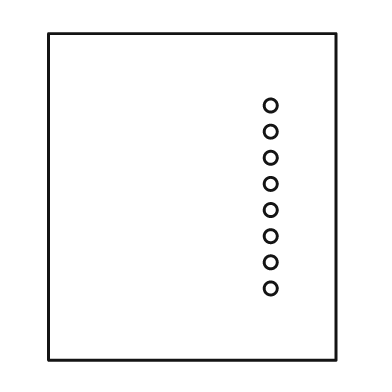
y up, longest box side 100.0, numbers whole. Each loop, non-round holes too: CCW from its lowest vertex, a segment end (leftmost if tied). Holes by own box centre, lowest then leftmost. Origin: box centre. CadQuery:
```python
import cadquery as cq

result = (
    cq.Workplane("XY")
    .moveTo(-44.0, -50.0)
    .lineTo(44.0, -50.0)
    .lineTo(44.0, 50.0)
    .lineTo(-44.0, 50.0)
    .close()
    .moveTo(24.0, -28.0)
    .circle(2.0)
    .moveTo(24.0, -20.0)
    .circle(2.0)
    .moveTo(24.0, -12.0)
    .circle(2.0)
    .moveTo(24.0, -4.0)
    .circle(2.0)
    .moveTo(24.0, 4.0)
    .circle(2.0)
    .moveTo(24.0, 12.0)
    .circle(2.0)
    .moveTo(24.0, 20.0)
    .circle(2.0)
    .moveTo(24.0, 28.0)
    .circle(2.0)
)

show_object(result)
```